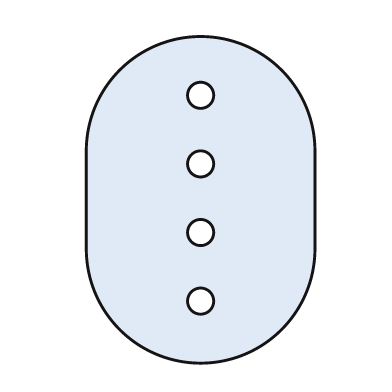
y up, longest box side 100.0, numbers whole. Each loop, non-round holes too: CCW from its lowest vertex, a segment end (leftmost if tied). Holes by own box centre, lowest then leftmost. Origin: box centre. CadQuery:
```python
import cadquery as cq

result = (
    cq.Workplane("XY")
    .moveTo(-35.0, -15.0)
    .threePointArc((0.0, -50.0), (35.0, -15.0))
    .lineTo(35.0, 15.0)
    .threePointArc((0.0, 50.0), (-35.0, 15.0))
    .close()
    .moveTo(0.0, -31.0)
    .circle(4.0)
    .moveTo(0.0, -10.0)
    .circle(4.0)
    .moveTo(0.0, 11.0)
    .circle(4.0)
    .moveTo(0.0, 32.0)
    .circle(4.0)
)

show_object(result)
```